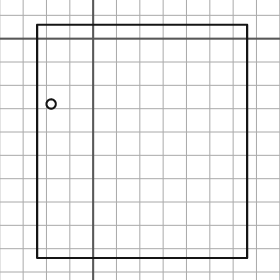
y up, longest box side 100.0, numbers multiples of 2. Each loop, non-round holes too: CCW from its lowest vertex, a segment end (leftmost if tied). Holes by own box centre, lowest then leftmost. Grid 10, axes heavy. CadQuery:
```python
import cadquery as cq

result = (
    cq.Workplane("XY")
    .moveTo(-24.0, -94.0)
    .lineTo(66.0, -94.0)
    .lineTo(66.0, 6.0)
    .lineTo(-24.0, 6.0)
    .close()
    .moveTo(-18.0, -28.0)
    .circle(2.0)
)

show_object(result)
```